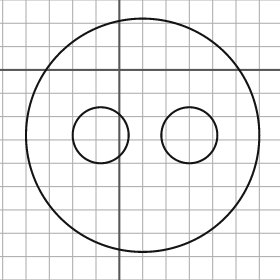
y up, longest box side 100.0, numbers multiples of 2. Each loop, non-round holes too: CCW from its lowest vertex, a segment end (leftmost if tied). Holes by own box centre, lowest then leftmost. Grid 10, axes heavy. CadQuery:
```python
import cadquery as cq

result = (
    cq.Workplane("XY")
    .moveTo(10.0, -28.0)
    .circle(50.0)
    .moveTo(-8.0, -28.0)
    .circle(12.0)
    .moveTo(30.0, -28.0)
    .circle(12.0)
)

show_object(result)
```